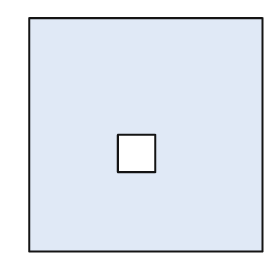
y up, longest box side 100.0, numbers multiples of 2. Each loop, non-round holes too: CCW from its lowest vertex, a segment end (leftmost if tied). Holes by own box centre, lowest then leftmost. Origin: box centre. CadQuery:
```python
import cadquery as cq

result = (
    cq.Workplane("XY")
    .moveTo(-50.0, -50.0)
    .lineTo(50.0, -50.0)
    .lineTo(50.0, 50.0)
    .lineTo(-50.0, 50.0)
    .close()
    .moveTo(-12.0, -16.0)
    .lineTo(4.0, -16.0)
    .lineTo(4.0, 0.0)
    .lineTo(-12.0, 0.0)
    .close()
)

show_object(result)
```